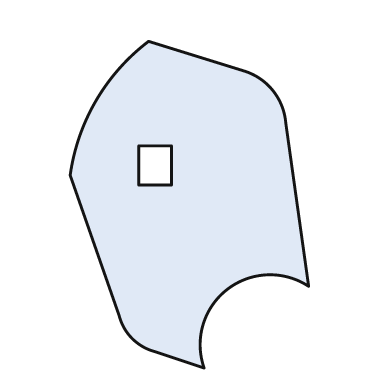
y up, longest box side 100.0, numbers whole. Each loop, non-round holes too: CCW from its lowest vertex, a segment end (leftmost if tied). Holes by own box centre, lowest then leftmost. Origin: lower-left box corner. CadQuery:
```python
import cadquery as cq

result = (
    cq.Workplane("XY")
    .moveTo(41.0, 0.0)
    .threePointArc((48.0, 24.0), (73.0, 25.0))
    .lineTo(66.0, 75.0)
    .threePointArc((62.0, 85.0), (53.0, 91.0))
    .lineTo(24.0, 100.0)
    .threePointArc((8.0, 82.0), (0.0, 59.0))
    .lineTo(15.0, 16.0)
    .threePointArc((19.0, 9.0), (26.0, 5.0))
    .close()
    .moveTo(21.0, 56.0)
    .lineTo(31.0, 56.0)
    .lineTo(31.0, 68.0)
    .lineTo(21.0, 68.0)
    .close()
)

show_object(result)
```